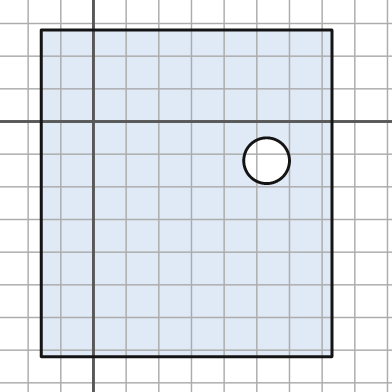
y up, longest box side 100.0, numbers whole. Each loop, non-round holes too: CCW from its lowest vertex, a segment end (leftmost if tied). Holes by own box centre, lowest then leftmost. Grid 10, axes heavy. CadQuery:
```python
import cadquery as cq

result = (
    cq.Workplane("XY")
    .moveTo(-16.0, -72.0)
    .lineTo(73.0, -72.0)
    .lineTo(73.0, 28.0)
    .lineTo(-16.0, 28.0)
    .close()
    .moveTo(53.0, -12.0)
    .circle(7.0)
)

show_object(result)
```